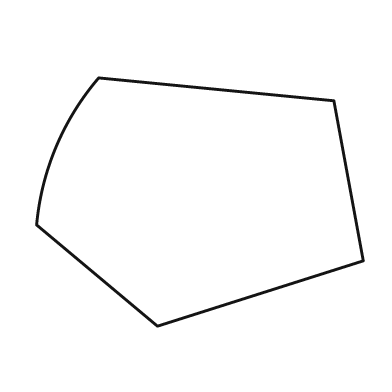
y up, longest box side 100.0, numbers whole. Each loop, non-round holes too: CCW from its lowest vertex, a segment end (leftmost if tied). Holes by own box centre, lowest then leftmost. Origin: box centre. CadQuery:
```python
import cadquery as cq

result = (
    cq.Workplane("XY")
    .moveTo(-13.0, -38.0)
    .lineTo(50.0, -18.0)
    .lineTo(41.0, 31.0)
    .lineTo(-31.0, 38.0)
    .threePointArc((-44.0, 17.0), (-50.0, -7.0))
    .close()
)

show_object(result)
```